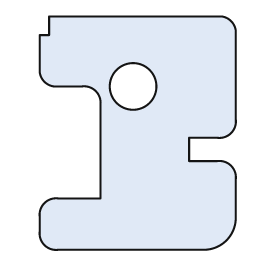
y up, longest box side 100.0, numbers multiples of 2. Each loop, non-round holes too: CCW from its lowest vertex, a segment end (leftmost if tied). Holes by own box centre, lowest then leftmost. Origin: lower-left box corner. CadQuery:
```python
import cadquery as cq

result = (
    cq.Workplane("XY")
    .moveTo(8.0, 0.0)
    .lineTo(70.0, 0.0)
    .threePointArc((80.0, 4.0), (84.0, 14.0))
    .lineTo(84.0, 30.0)
    .threePointArc((82.0, 36.0), (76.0, 38.0))
    .lineTo(64.0, 38.0)
    .lineTo(64.0, 48.0)
    .lineTo(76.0, 48.0)
    .threePointArc((82.0, 50.0), (84.0, 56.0))
    .lineTo(84.0, 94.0)
    .threePointArc((82.0, 98.0), (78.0, 100.0))
    .lineTo(4.0, 100.0)
    .lineTo(4.0, 92.0)
    .lineTo(0.0, 92.0)
    .lineTo(0.0, 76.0)
    .threePointArc((2.0, 72.0), (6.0, 70.0))
    .lineTo(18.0, 70.0)
    .threePointArc((24.0, 68.0), (26.0, 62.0))
    .lineTo(26.0, 22.0)
    .lineTo(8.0, 22.0)
    .threePointArc((2.0, 20.0), (0.0, 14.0))
    .lineTo(0.0, 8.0)
    .threePointArc((2.0, 2.0), (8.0, 0.0))
    .close()
    .moveTo(40.0, 70.0)
    .circle(10.0)
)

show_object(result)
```